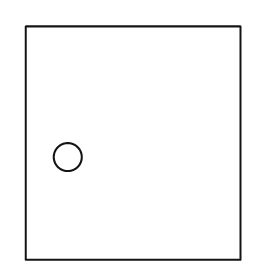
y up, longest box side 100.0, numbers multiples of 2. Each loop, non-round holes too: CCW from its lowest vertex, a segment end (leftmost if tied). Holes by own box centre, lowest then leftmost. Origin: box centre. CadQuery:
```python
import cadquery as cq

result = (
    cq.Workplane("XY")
    .moveTo(-46.0, -50.0)
    .lineTo(46.0, -50.0)
    .lineTo(46.0, 50.0)
    .lineTo(-46.0, 50.0)
    .close()
    .moveTo(-28.0, -6.0)
    .circle(6.0)
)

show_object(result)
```